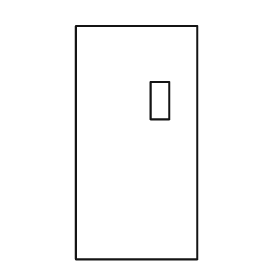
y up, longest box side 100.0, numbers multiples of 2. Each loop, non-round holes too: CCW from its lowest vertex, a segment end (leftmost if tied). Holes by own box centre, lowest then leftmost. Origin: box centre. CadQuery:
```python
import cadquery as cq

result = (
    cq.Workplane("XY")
    .moveTo(-26.0, -50.0)
    .lineTo(26.0, -50.0)
    .lineTo(26.0, 50.0)
    .lineTo(-26.0, 50.0)
    .close()
    .moveTo(6.0, 10.0)
    .lineTo(14.0, 10.0)
    .lineTo(14.0, 26.0)
    .lineTo(6.0, 26.0)
    .close()
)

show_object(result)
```